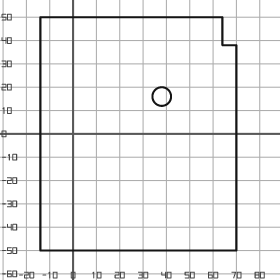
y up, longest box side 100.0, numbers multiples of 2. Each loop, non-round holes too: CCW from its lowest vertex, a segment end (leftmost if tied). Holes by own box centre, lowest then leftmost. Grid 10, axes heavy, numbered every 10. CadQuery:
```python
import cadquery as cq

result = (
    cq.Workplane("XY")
    .moveTo(-14.0, -50.0)
    .lineTo(70.0, -50.0)
    .lineTo(70.0, 38.0)
    .lineTo(64.0, 38.0)
    .lineTo(64.0, 50.0)
    .lineTo(-14.0, 50.0)
    .close()
    .moveTo(38.0, 16.0)
    .circle(4.0)
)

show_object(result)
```